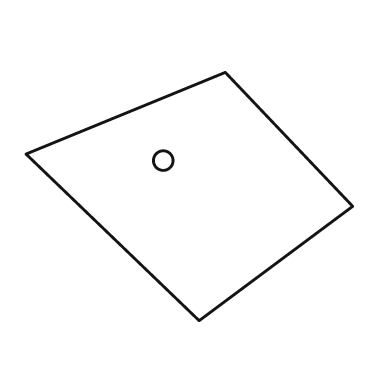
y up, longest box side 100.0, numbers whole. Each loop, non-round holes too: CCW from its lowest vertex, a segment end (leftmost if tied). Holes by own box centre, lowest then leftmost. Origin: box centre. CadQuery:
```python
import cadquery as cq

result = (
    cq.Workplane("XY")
    .moveTo(3.0, -38.0)
    .lineTo(50.0, -3.0)
    .lineTo(11.0, 38.0)
    .lineTo(-50.0, 13.0)
    .close()
    .moveTo(-8.0, 11.0)
    .circle(3.0)
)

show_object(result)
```